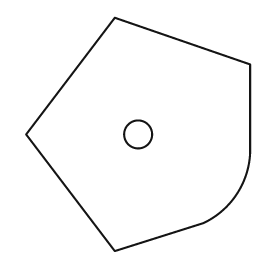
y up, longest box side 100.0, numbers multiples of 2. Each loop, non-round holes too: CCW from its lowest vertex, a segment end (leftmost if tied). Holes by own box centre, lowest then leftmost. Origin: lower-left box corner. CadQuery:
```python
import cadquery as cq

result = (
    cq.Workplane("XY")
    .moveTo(38.0, 0.0)
    .lineTo(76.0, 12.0)
    .threePointArc((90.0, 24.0), (96.0, 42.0))
    .lineTo(96.0, 80.0)
    .lineTo(38.0, 100.0)
    .lineTo(0.0, 50.0)
    .close()
    .moveTo(48.0, 50.0)
    .circle(6.0)
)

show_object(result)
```